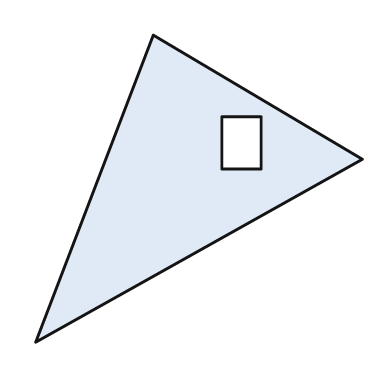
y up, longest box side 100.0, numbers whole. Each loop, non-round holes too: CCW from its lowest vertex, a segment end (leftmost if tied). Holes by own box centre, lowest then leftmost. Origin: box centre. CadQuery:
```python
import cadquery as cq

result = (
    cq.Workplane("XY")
    .moveTo(-50.0, -47.0)
    .lineTo(50.0, 9.0)
    .lineTo(-14.0, 47.0)
    .close()
    .moveTo(7.0, 6.0)
    .lineTo(19.0, 6.0)
    .lineTo(19.0, 22.0)
    .lineTo(7.0, 22.0)
    .close()
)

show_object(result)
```